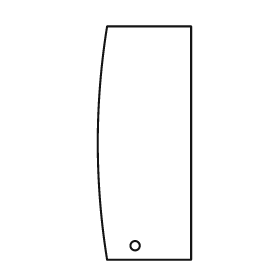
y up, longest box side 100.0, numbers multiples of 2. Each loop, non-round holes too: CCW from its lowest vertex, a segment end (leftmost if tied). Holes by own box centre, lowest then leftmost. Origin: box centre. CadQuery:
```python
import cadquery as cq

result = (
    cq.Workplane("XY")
    .moveTo(-16.0, -50.0)
    .lineTo(20.0, -50.0)
    .lineTo(20.0, 50.0)
    .lineTo(-16.0, 50.0)
    .threePointArc((-20.0, 0.0), (-16.0, -50.0))
    .close()
    .moveTo(-4.0, -44.0)
    .circle(2.0)
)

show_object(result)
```